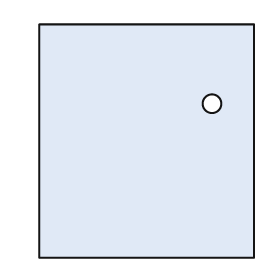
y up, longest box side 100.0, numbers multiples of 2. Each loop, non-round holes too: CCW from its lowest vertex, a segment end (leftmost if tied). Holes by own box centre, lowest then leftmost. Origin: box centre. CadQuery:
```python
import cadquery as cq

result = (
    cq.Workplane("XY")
    .moveTo(-46.0, -50.0)
    .lineTo(46.0, -50.0)
    .lineTo(46.0, 50.0)
    .lineTo(-46.0, 50.0)
    .close()
    .moveTo(28.0, 16.0)
    .circle(4.0)
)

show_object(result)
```